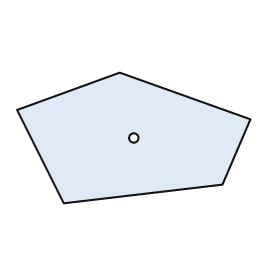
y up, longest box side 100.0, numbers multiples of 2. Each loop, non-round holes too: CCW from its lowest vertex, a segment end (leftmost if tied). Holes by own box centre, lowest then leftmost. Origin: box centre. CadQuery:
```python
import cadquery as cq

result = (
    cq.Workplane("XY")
    .moveTo(-30.0, -28.0)
    .lineTo(38.0, -20.0)
    .lineTo(50.0, 8.0)
    .lineTo(-6.0, 28.0)
    .lineTo(-50.0, 12.0)
    .close()
    .moveTo(0.0, 0.0)
    .circle(2.0)
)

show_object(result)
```